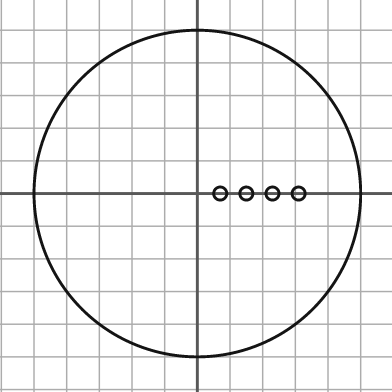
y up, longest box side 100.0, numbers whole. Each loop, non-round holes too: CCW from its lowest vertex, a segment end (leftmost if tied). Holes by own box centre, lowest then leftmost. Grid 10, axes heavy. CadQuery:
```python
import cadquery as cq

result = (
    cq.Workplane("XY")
    .moveTo(0.0, 0.0)
    .circle(50.0)
    .moveTo(7.0, 0.0)
    .circle(2.0)
    .moveTo(15.0, 0.0)
    .circle(2.0)
    .moveTo(23.0, 0.0)
    .circle(2.0)
    .moveTo(31.0, 0.0)
    .circle(2.0)
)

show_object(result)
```